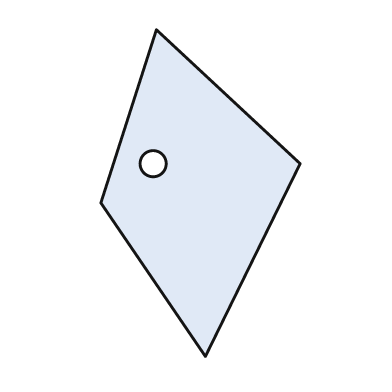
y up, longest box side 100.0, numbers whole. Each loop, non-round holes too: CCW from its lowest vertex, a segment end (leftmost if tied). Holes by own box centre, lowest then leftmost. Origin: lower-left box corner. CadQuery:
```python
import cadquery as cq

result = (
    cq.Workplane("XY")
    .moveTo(32.0, 0.0)
    .lineTo(61.0, 59.0)
    .lineTo(17.0, 100.0)
    .lineTo(0.0, 47.0)
    .close()
    .moveTo(16.0, 59.0)
    .circle(4.0)
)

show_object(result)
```